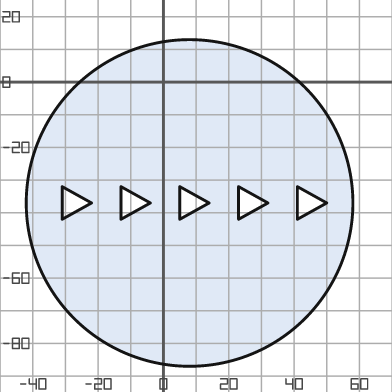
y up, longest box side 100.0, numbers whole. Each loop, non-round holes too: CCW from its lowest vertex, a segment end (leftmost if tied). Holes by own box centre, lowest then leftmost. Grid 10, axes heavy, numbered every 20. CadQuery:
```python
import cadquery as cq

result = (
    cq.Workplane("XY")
    .moveTo(8.0, -37.0)
    .circle(50.0)
    .moveTo(-31.0, -42.0)
    .lineTo(-22.0, -37.0)
    .lineTo(-31.0, -32.0)
    .close()
    .moveTo(-13.0, -42.0)
    .lineTo(-4.0, -37.0)
    .lineTo(-13.0, -32.0)
    .close()
    .moveTo(5.0, -42.0)
    .lineTo(14.0, -37.0)
    .lineTo(5.0, -32.0)
    .close()
    .moveTo(23.0, -42.0)
    .lineTo(32.0, -37.0)
    .lineTo(23.0, -32.0)
    .close()
    .moveTo(41.0, -42.0)
    .lineTo(50.0, -37.0)
    .lineTo(41.0, -32.0)
    .close()
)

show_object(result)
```